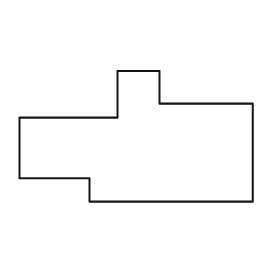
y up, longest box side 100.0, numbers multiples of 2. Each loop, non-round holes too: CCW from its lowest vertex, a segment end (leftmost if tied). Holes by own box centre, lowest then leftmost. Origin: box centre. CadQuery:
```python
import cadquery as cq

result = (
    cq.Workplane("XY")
    .moveTo(-20.0, -28.0)
    .lineTo(50.0, -28.0)
    .lineTo(50.0, 14.0)
    .lineTo(10.0, 14.0)
    .lineTo(10.0, 28.0)
    .lineTo(-8.0, 28.0)
    .lineTo(-8.0, 8.0)
    .lineTo(-50.0, 8.0)
    .lineTo(-50.0, -18.0)
    .lineTo(-20.0, -18.0)
    .close()
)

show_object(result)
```